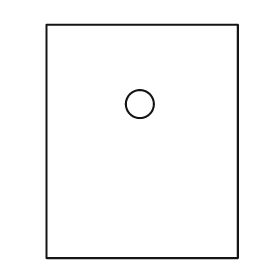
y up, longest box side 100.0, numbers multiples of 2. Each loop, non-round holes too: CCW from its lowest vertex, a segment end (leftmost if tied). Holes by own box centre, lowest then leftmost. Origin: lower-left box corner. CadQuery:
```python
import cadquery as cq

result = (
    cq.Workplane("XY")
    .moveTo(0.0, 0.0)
    .lineTo(82.0, 0.0)
    .lineTo(82.0, 100.0)
    .lineTo(0.0, 100.0)
    .close()
    .moveTo(40.0, 66.0)
    .circle(6.0)
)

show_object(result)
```